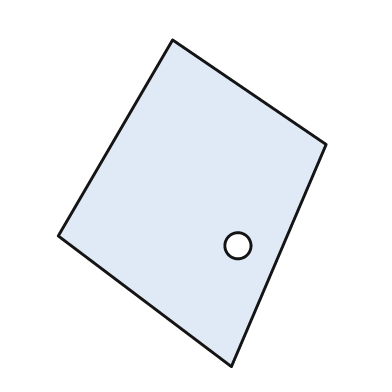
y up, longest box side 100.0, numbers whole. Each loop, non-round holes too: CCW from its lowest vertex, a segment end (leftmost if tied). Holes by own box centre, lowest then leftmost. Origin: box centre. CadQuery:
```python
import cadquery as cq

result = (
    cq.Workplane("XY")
    .moveTo(12.0, -50.0)
    .lineTo(41.0, 18.0)
    .lineTo(-6.0, 50.0)
    .lineTo(-41.0, -10.0)
    .close()
    .moveTo(14.0, -13.0)
    .circle(4.0)
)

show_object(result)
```